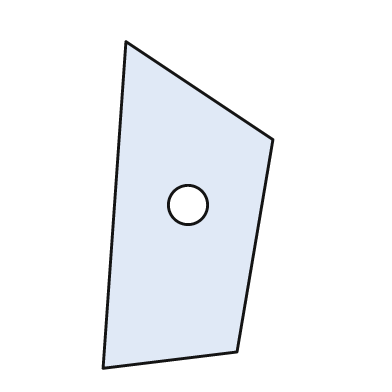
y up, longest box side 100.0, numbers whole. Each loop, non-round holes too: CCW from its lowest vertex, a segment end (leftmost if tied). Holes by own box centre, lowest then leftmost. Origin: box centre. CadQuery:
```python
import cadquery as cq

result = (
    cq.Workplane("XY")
    .moveTo(-26.0, -50.0)
    .lineTo(15.0, -45.0)
    .lineTo(26.0, 20.0)
    .lineTo(-19.0, 50.0)
    .close()
    .moveTo(0.0, 0.0)
    .circle(6.0)
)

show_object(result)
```